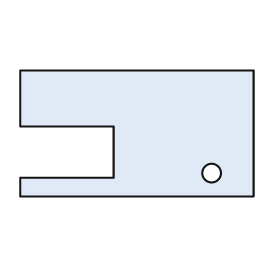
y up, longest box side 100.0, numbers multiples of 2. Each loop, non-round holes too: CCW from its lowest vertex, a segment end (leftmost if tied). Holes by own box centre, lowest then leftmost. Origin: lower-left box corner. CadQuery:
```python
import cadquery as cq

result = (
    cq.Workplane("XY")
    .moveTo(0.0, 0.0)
    .lineTo(100.0, 0.0)
    .lineTo(100.0, 54.0)
    .lineTo(0.0, 54.0)
    .lineTo(0.0, 30.0)
    .lineTo(40.0, 30.0)
    .lineTo(40.0, 8.0)
    .lineTo(0.0, 8.0)
    .close()
    .moveTo(82.0, 10.0)
    .circle(4.0)
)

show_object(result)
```